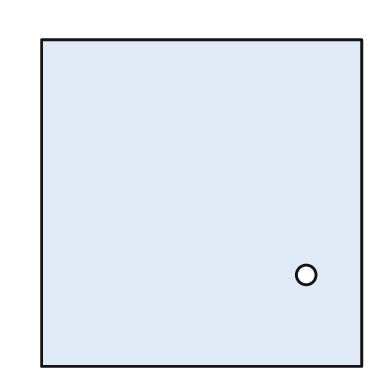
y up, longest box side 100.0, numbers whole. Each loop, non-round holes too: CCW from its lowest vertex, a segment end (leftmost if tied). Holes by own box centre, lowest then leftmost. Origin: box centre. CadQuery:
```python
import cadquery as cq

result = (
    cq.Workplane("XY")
    .moveTo(-49.0, -50.0)
    .lineTo(49.0, -50.0)
    .lineTo(49.0, 50.0)
    .lineTo(-49.0, 50.0)
    .close()
    .moveTo(32.0, -22.0)
    .circle(3.0)
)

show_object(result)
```